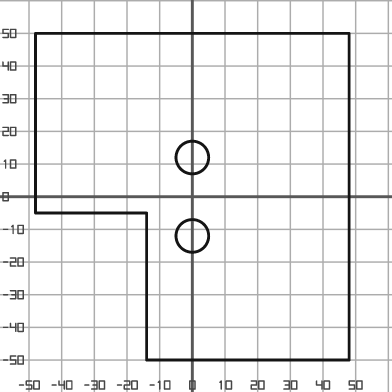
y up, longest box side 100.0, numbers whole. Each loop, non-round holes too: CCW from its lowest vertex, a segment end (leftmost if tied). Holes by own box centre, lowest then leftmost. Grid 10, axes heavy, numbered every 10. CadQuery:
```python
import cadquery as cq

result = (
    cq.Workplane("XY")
    .moveTo(-14.0, -50.0)
    .lineTo(48.0, -50.0)
    .lineTo(48.0, 50.0)
    .lineTo(-48.0, 50.0)
    .lineTo(-48.0, -5.0)
    .lineTo(-14.0, -5.0)
    .close()
    .moveTo(0.0, -12.0)
    .circle(5.0)
    .moveTo(0.0, 12.0)
    .circle(5.0)
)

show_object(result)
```